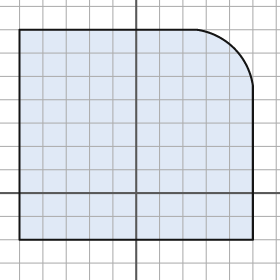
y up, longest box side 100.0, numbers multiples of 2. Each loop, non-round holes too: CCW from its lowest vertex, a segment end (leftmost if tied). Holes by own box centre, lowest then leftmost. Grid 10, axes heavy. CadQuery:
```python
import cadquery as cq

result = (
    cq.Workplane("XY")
    .moveTo(-50.0, -20.0)
    .lineTo(50.0, -20.0)
    .lineTo(50.0, 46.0)
    .threePointArc((42.0, 62.0), (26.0, 70.0))
    .lineTo(-50.0, 70.0)
    .close()
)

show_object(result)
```